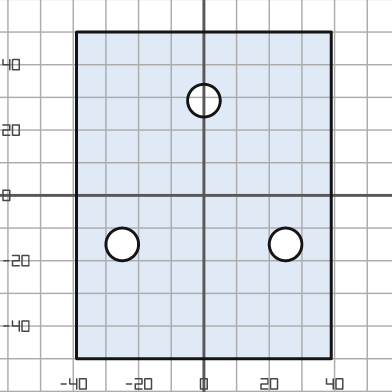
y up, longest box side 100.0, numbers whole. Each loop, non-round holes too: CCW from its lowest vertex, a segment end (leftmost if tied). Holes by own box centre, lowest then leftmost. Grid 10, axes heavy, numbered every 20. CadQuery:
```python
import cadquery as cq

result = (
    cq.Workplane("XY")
    .moveTo(-39.0, -50.0)
    .lineTo(39.0, -50.0)
    .lineTo(39.0, 50.0)
    .lineTo(-39.0, 50.0)
    .close()
    .moveTo(-25.0, -15.0)
    .circle(5.0)
    .moveTo(25.0, -15.0)
    .circle(5.0)
    .moveTo(0.0, 29.0)
    .circle(5.0)
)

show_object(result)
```